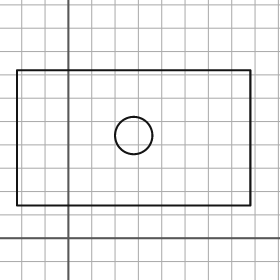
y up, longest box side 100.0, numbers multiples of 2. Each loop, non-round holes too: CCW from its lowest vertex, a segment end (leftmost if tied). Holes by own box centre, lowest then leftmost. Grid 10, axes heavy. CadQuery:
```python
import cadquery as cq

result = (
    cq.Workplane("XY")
    .moveTo(-22.0, 14.0)
    .lineTo(78.0, 14.0)
    .lineTo(78.0, 72.0)
    .lineTo(-22.0, 72.0)
    .close()
    .moveTo(28.0, 44.0)
    .circle(8.0)
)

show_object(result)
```